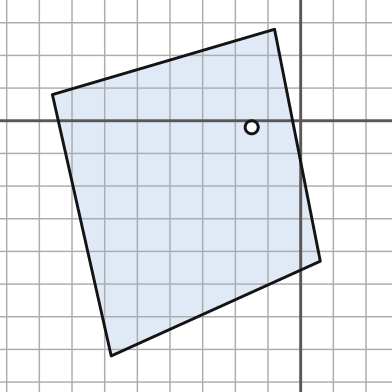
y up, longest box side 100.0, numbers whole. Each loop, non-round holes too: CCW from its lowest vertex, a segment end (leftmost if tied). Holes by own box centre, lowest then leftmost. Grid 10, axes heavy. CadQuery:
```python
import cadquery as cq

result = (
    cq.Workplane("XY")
    .moveTo(-58.0, -72.0)
    .lineTo(6.0, -43.0)
    .lineTo(-8.0, 28.0)
    .lineTo(-76.0, 8.0)
    .close()
    .moveTo(-15.0, -2.0)
    .circle(2.0)
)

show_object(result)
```